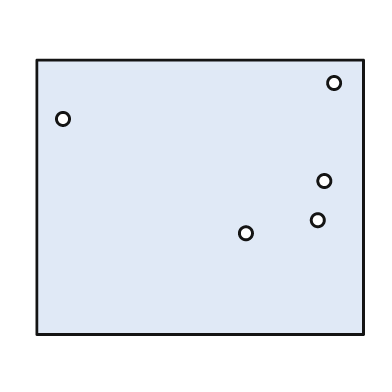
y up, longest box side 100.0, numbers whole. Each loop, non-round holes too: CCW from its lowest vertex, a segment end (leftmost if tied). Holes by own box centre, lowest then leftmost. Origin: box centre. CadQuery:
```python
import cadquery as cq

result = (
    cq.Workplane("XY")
    .moveTo(-50.0, -42.0)
    .lineTo(50.0, -42.0)
    .lineTo(50.0, 42.0)
    .lineTo(-50.0, 42.0)
    .close()
    .moveTo(14.0, -11.0)
    .circle(2.0)
    .moveTo(36.0, -7.0)
    .circle(2.0)
    .moveTo(38.0, 5.0)
    .circle(2.0)
    .moveTo(-42.0, 24.0)
    .circle(2.0)
    .moveTo(41.0, 35.0)
    .circle(2.0)
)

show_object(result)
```